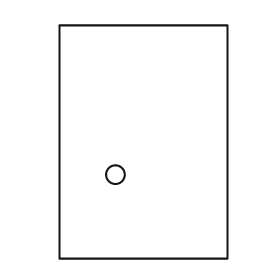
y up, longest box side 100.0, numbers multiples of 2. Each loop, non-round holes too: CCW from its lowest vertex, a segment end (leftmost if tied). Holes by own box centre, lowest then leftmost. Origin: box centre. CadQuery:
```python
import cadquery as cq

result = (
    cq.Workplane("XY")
    .moveTo(-36.0, -50.0)
    .lineTo(36.0, -50.0)
    .lineTo(36.0, 50.0)
    .lineTo(-36.0, 50.0)
    .close()
    .moveTo(-12.0, -14.0)
    .circle(4.0)
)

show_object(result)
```